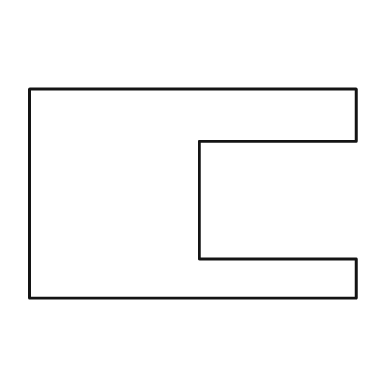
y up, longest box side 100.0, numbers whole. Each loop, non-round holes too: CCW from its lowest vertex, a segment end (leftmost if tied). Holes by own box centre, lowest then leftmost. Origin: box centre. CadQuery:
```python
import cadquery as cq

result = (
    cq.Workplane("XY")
    .moveTo(-50.0, -32.0)
    .lineTo(50.0, -32.0)
    .lineTo(50.0, -20.0)
    .lineTo(2.0, -20.0)
    .lineTo(2.0, 16.0)
    .lineTo(50.0, 16.0)
    .lineTo(50.0, 32.0)
    .lineTo(-50.0, 32.0)
    .close()
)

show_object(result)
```